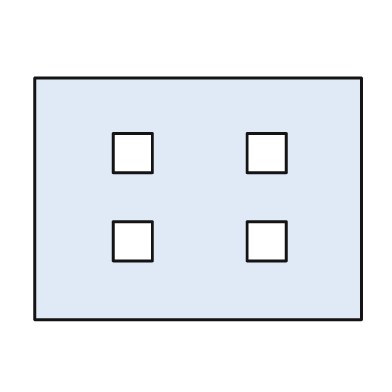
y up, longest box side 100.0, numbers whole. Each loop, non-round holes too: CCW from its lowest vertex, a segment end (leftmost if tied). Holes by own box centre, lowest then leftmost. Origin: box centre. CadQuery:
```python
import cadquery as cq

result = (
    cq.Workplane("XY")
    .moveTo(-50.0, -37.0)
    .lineTo(50.0, -37.0)
    .lineTo(50.0, 37.0)
    .lineTo(-50.0, 37.0)
    .close()
    .moveTo(-26.0, -19.0)
    .lineTo(-14.0, -19.0)
    .lineTo(-14.0, -7.0)
    .lineTo(-26.0, -7.0)
    .close()
    .moveTo(15.0, -19.0)
    .lineTo(27.0, -19.0)
    .lineTo(27.0, -7.0)
    .lineTo(15.0, -7.0)
    .close()
    .moveTo(-26.0, 8.0)
    .lineTo(-14.0, 8.0)
    .lineTo(-14.0, 20.0)
    .lineTo(-26.0, 20.0)
    .close()
    .moveTo(15.0, 8.0)
    .lineTo(27.0, 8.0)
    .lineTo(27.0, 20.0)
    .lineTo(15.0, 20.0)
    .close()
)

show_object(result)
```